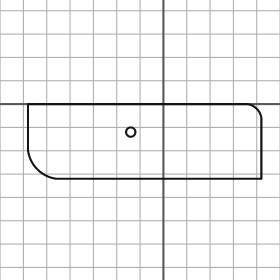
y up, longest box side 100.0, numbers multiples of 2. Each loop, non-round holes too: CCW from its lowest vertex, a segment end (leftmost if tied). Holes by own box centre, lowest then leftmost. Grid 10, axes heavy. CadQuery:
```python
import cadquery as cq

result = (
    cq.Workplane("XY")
    .moveTo(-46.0, -32.0)
    .lineTo(42.0, -32.0)
    .lineTo(42.0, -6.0)
    .threePointArc((40.0, -2.0), (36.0, 0.0))
    .lineTo(-58.0, 0.0)
    .lineTo(-58.0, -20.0)
    .threePointArc((-54.0, -28.0), (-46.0, -32.0))
    .close()
    .moveTo(-14.0, -12.0)
    .circle(2.0)
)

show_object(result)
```